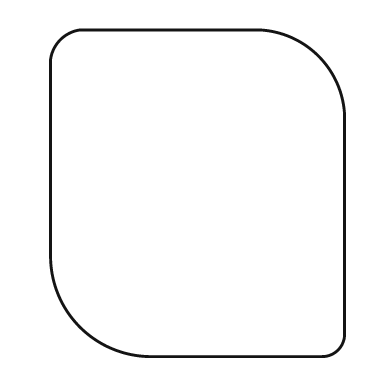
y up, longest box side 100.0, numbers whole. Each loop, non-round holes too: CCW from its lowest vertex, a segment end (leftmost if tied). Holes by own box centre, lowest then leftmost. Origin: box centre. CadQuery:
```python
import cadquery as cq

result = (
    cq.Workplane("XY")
    .moveTo(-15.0, -50.0)
    .lineTo(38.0, -50.0)
    .threePointArc((43.0, -48.0), (45.0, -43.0))
    .lineTo(45.0, 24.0)
    .threePointArc((37.0, 42.0), (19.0, 50.0))
    .lineTo(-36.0, 50.0)
    .threePointArc((-42.0, 47.0), (-45.0, 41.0))
    .lineTo(-45.0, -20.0)
    .threePointArc((-36.0, -41.0), (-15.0, -50.0))
    .close()
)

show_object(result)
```